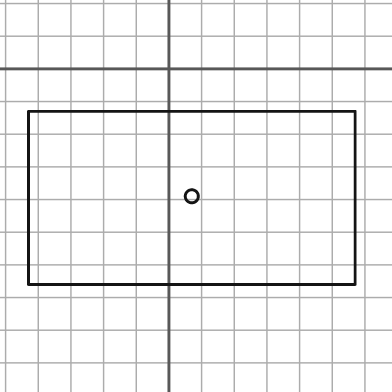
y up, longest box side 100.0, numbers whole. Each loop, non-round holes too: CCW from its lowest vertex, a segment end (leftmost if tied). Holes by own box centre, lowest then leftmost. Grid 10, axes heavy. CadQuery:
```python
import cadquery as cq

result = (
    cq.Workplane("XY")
    .moveTo(-43.0, -66.0)
    .lineTo(57.0, -66.0)
    .lineTo(57.0, -13.0)
    .lineTo(-43.0, -13.0)
    .close()
    .moveTo(7.0, -39.0)
    .circle(2.0)
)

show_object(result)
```